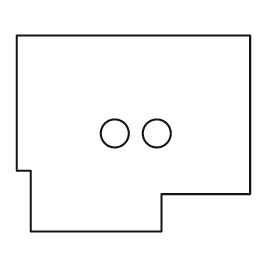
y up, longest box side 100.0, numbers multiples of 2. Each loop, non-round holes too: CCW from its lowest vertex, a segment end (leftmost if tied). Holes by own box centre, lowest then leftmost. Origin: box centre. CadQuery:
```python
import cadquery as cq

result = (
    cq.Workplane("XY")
    .moveTo(-44.0, -42.0)
    .lineTo(12.0, -42.0)
    .lineTo(12.0, -26.0)
    .lineTo(50.0, -26.0)
    .lineTo(50.0, 42.0)
    .lineTo(-50.0, 42.0)
    .lineTo(-50.0, -16.0)
    .lineTo(-44.0, -16.0)
    .close()
    .moveTo(-8.0, 0.0)
    .circle(6.0)
    .moveTo(10.0, 0.0)
    .circle(6.0)
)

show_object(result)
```